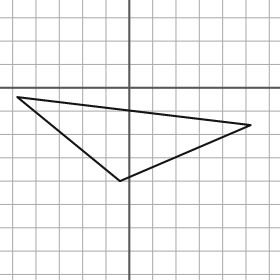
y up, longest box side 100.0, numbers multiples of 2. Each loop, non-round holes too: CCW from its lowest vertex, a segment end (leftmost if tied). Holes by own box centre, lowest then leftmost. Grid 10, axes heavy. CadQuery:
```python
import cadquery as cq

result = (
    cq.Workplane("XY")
    .moveTo(-4.0, -40.0)
    .lineTo(52.0, -16.0)
    .lineTo(-48.0, -4.0)
    .close()
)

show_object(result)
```